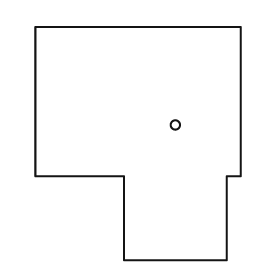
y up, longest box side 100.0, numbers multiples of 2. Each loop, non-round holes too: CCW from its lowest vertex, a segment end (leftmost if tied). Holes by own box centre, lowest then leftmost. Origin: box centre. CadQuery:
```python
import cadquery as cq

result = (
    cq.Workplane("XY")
    .moveTo(-6.0, -50.0)
    .lineTo(38.0, -50.0)
    .lineTo(38.0, -14.0)
    .lineTo(44.0, -14.0)
    .lineTo(44.0, 50.0)
    .lineTo(-44.0, 50.0)
    .lineTo(-44.0, -14.0)
    .lineTo(-6.0, -14.0)
    .close()
    .moveTo(16.0, 8.0)
    .circle(2.0)
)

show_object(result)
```